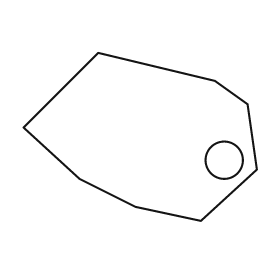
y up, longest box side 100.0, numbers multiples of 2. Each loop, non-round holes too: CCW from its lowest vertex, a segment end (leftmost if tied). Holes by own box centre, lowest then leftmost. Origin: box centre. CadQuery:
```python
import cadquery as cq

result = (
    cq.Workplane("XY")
    .moveTo(26.0, -36.0)
    .lineTo(50.0, -14.0)
    .lineTo(46.0, 14.0)
    .lineTo(32.0, 24.0)
    .lineTo(-18.0, 36.0)
    .lineTo(-50.0, 4.0)
    .lineTo(-26.0, -18.0)
    .lineTo(-2.0, -30.0)
    .close()
    .moveTo(36.0, -10.0)
    .circle(8.0)
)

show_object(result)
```